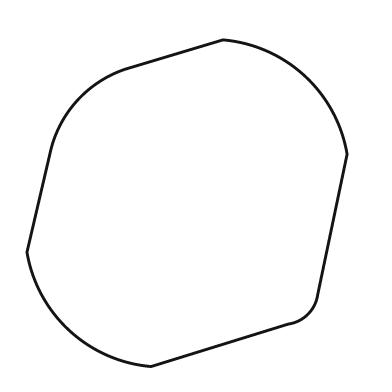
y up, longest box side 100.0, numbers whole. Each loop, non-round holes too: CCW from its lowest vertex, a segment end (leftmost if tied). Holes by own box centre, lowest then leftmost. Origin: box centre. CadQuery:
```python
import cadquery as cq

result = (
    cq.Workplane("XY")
    .moveTo(-11.0, -50.0)
    .lineTo(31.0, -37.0)
    .threePointArc((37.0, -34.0), (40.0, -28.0))
    .lineTo(49.0, 15.0)
    .threePointArc((36.0, 39.0), (11.0, 50.0))
    .lineTo(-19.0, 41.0)
    .threePointArc((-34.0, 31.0), (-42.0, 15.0))
    .lineTo(-49.0, -15.0)
    .threePointArc((-36.0, -39.0), (-11.0, -50.0))
    .close()
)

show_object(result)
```